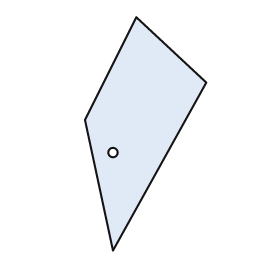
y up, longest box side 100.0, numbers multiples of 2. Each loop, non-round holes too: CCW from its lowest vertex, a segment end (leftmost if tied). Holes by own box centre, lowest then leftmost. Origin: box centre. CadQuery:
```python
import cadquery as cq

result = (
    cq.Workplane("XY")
    .moveTo(-14.0, -50.0)
    .lineTo(26.0, 22.0)
    .lineTo(-4.0, 50.0)
    .lineTo(-26.0, 6.0)
    .close()
    .moveTo(-14.0, -8.0)
    .circle(2.0)
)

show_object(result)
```